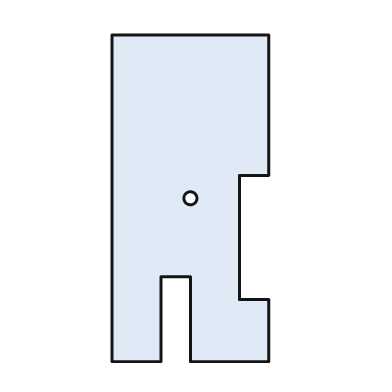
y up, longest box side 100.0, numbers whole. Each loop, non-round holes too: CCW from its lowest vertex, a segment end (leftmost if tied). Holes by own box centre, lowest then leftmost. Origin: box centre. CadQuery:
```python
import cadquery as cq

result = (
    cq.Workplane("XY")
    .moveTo(-24.0, -50.0)
    .lineTo(-9.0, -50.0)
    .lineTo(-9.0, -24.0)
    .lineTo(0.0, -24.0)
    .lineTo(0.0, -50.0)
    .lineTo(24.0, -50.0)
    .lineTo(24.0, -31.0)
    .lineTo(15.0, -31.0)
    .lineTo(15.0, 7.0)
    .lineTo(24.0, 7.0)
    .lineTo(24.0, 50.0)
    .lineTo(-24.0, 50.0)
    .close()
    .moveTo(0.0, 0.0)
    .circle(2.0)
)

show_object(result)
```